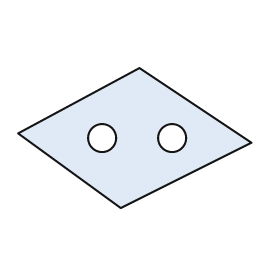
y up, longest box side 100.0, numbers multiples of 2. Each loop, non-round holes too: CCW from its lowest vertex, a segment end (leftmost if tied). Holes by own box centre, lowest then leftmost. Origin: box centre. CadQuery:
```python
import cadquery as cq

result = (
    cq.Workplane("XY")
    .moveTo(-6.0, -30.0)
    .lineTo(50.0, -2.0)
    .lineTo(2.0, 30.0)
    .lineTo(-50.0, 2.0)
    .close()
    .moveTo(-14.0, 0.0)
    .circle(6.0)
    .moveTo(16.0, 0.0)
    .circle(6.0)
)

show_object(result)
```